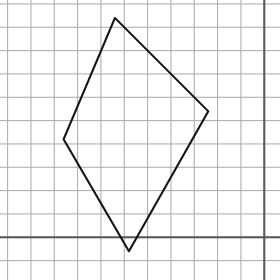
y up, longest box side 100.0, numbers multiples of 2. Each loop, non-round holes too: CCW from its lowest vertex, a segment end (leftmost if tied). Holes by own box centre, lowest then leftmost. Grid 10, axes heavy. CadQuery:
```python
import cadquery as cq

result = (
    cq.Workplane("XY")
    .moveTo(-58.0, -6.0)
    .lineTo(-24.0, 54.0)
    .lineTo(-64.0, 94.0)
    .lineTo(-86.0, 42.0)
    .close()
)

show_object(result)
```